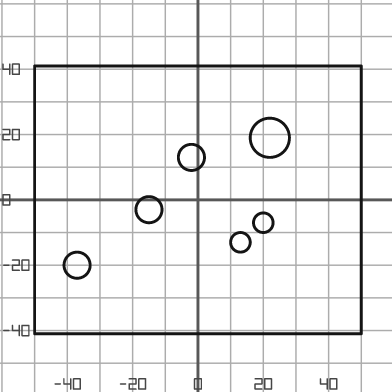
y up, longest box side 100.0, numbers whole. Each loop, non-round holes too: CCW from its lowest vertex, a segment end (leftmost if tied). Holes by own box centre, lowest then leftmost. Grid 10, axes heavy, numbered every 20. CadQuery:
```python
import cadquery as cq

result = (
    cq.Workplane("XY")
    .moveTo(-50.0, -41.0)
    .lineTo(50.0, -41.0)
    .lineTo(50.0, 41.0)
    .lineTo(-50.0, 41.0)
    .close()
    .moveTo(-37.0, -20.0)
    .circle(4.0)
    .moveTo(13.0, -13.0)
    .circle(3.0)
    .moveTo(20.0, -7.0)
    .circle(3.0)
    .moveTo(-15.0, -3.0)
    .circle(4.0)
    .moveTo(-2.0, 13.0)
    .circle(4.0)
    .moveTo(22.0, 19.0)
    .circle(6.0)
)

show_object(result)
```